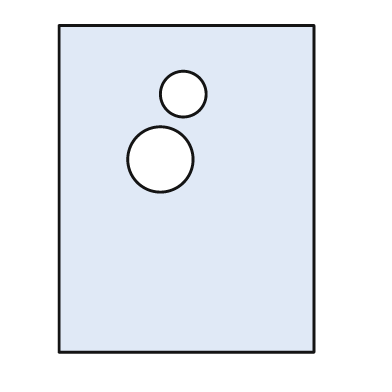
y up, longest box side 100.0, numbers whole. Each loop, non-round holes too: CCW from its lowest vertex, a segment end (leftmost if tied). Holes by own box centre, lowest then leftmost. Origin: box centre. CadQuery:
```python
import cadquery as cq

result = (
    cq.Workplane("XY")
    .moveTo(-39.0, -50.0)
    .lineTo(39.0, -50.0)
    .lineTo(39.0, 50.0)
    .lineTo(-39.0, 50.0)
    .close()
    .moveTo(-8.0, 9.0)
    .circle(10.0)
    .moveTo(-1.0, 29.0)
    .circle(7.0)
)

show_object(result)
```